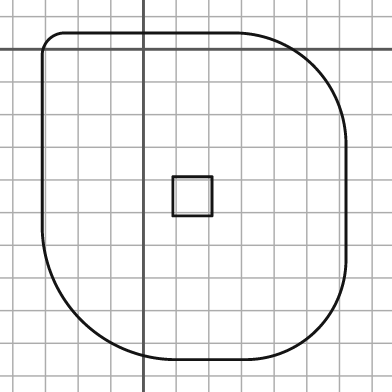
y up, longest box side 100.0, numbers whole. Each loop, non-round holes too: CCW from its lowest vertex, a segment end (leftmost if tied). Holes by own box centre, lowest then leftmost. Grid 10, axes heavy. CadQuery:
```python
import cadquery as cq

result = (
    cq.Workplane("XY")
    .moveTo(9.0, -95.0)
    .lineTo(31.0, -95.0)
    .threePointArc((53.0, -86.0), (62.0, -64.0))
    .lineTo(62.0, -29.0)
    .threePointArc((52.0, -5.0), (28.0, 5.0))
    .lineTo(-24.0, 5.0)
    .threePointArc((-29.0, 3.0), (-31.0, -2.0))
    .lineTo(-31.0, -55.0)
    .threePointArc((-19.0, -83.0), (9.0, -95.0))
    .close()
    .moveTo(9.0, -51.0)
    .lineTo(21.0, -51.0)
    .lineTo(21.0, -39.0)
    .lineTo(9.0, -39.0)
    .close()
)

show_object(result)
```